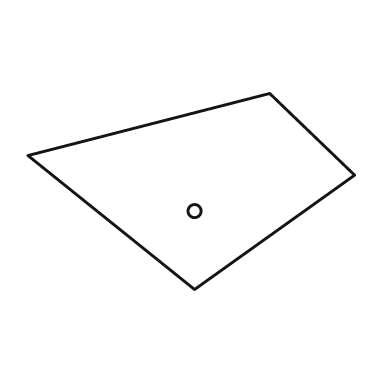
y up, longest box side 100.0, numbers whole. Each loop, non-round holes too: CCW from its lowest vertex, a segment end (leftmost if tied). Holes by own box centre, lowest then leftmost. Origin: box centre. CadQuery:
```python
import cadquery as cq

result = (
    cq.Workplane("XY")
    .moveTo(1.0, -30.0)
    .lineTo(50.0, 5.0)
    .lineTo(24.0, 30.0)
    .lineTo(-50.0, 11.0)
    .close()
    .moveTo(1.0, -6.0)
    .circle(2.0)
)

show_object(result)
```